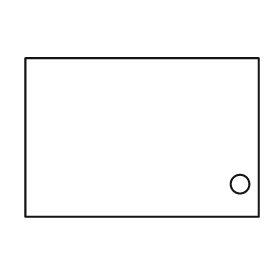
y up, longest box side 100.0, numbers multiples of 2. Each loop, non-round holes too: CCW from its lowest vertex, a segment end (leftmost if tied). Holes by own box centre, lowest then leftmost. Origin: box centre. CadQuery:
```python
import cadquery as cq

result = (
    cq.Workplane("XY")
    .moveTo(-50.0, -34.0)
    .lineTo(50.0, -34.0)
    .lineTo(50.0, 34.0)
    .lineTo(-50.0, 34.0)
    .close()
    .moveTo(42.0, -20.0)
    .circle(4.0)
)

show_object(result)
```